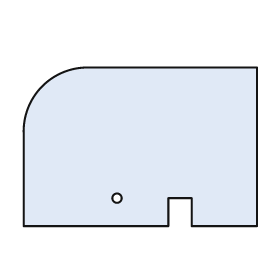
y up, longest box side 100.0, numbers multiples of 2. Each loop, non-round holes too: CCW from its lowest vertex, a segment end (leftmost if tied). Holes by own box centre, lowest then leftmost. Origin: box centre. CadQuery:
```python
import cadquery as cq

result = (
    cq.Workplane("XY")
    .moveTo(-50.0, -34.0)
    .lineTo(12.0, -34.0)
    .lineTo(12.0, -22.0)
    .lineTo(22.0, -22.0)
    .lineTo(22.0, -34.0)
    .lineTo(50.0, -34.0)
    .lineTo(50.0, 34.0)
    .lineTo(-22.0, 34.0)
    .threePointArc((-42.0, 26.0), (-50.0, 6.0))
    .close()
    .moveTo(-10.0, -22.0)
    .circle(2.0)
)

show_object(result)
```